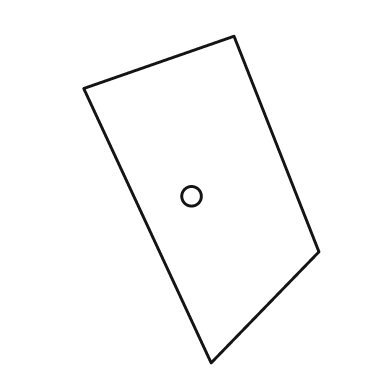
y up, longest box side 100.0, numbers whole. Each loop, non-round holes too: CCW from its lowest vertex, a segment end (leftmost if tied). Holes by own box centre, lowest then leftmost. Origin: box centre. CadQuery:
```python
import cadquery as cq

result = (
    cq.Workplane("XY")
    .moveTo(3.0, -50.0)
    .lineTo(36.0, -16.0)
    .lineTo(10.0, 50.0)
    .lineTo(-36.0, 34.0)
    .close()
    .moveTo(-3.0, 1.0)
    .circle(3.0)
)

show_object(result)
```